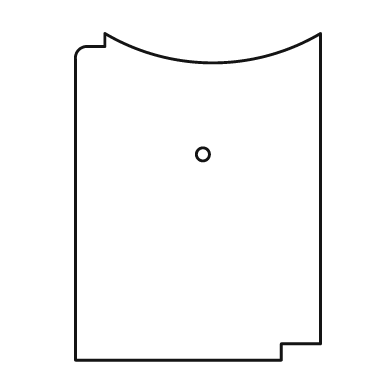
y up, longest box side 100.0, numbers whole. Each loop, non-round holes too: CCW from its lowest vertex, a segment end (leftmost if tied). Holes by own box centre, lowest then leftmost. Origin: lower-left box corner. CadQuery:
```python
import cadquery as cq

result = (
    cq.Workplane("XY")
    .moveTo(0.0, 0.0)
    .lineTo(63.0, 0.0)
    .lineTo(63.0, 5.0)
    .lineTo(75.0, 5.0)
    .lineTo(75.0, 100.0)
    .threePointArc((42.0, 91.0), (9.0, 100.0))
    .lineTo(9.0, 96.0)
    .lineTo(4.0, 96.0)
    .threePointArc((1.0, 95.0), (0.0, 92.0))
    .close()
    .moveTo(39.0, 63.0)
    .circle(2.0)
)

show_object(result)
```